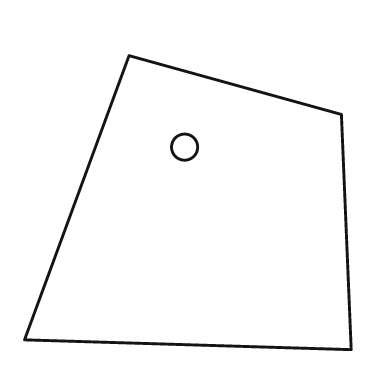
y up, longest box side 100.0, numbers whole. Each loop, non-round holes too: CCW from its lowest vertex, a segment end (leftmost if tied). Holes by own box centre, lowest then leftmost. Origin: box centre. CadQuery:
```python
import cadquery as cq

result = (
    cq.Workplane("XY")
    .moveTo(50.0, -45.0)
    .lineTo(47.0, 27.0)
    .lineTo(-18.0, 45.0)
    .lineTo(-50.0, -42.0)
    .close()
    .moveTo(-1.0, 17.0)
    .circle(4.0)
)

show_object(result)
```